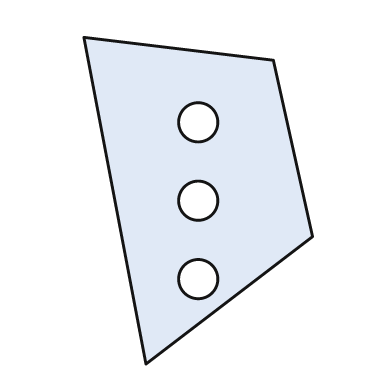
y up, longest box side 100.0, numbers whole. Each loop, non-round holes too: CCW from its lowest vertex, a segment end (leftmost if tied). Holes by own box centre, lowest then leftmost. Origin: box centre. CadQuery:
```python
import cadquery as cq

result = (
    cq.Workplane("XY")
    .moveTo(-16.0, -50.0)
    .lineTo(35.0, -11.0)
    .lineTo(23.0, 43.0)
    .lineTo(-35.0, 50.0)
    .close()
    .moveTo(0.0, -24.0)
    .circle(6.0)
    .moveTo(0.0, 0.0)
    .circle(6.0)
    .moveTo(0.0, 24.0)
    .circle(6.0)
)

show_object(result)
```